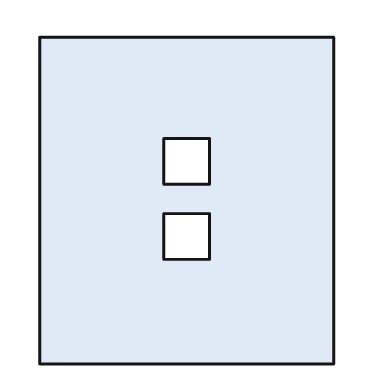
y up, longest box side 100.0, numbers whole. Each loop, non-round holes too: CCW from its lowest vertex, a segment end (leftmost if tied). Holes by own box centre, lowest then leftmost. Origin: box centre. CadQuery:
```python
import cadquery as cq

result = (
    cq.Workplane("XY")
    .moveTo(-45.0, -50.0)
    .lineTo(45.0, -50.0)
    .lineTo(45.0, 50.0)
    .lineTo(-45.0, 50.0)
    .close()
    .moveTo(-7.0, -18.0)
    .lineTo(7.0, -18.0)
    .lineTo(7.0, -4.0)
    .lineTo(-7.0, -4.0)
    .close()
    .moveTo(-7.0, 5.0)
    .lineTo(7.0, 5.0)
    .lineTo(7.0, 19.0)
    .lineTo(-7.0, 19.0)
    .close()
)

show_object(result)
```